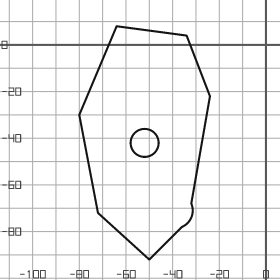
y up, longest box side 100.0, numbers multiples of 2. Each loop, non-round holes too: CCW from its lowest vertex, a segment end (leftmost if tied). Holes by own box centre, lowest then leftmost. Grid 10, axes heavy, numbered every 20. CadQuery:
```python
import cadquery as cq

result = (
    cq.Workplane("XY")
    .moveTo(-50.0, -92.0)
    .lineTo(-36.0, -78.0)
    .threePointArc((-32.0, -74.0), (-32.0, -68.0))
    .lineTo(-24.0, -22.0)
    .lineTo(-34.0, 4.0)
    .lineTo(-64.0, 8.0)
    .lineTo(-80.0, -30.0)
    .lineTo(-72.0, -72.0)
    .close()
    .moveTo(-52.0, -42.0)
    .circle(6.0)
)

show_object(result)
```